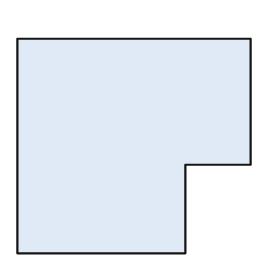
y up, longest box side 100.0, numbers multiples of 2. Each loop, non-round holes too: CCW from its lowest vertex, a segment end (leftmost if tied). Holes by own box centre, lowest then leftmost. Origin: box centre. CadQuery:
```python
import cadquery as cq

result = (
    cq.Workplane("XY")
    .moveTo(-50.0, -46.0)
    .lineTo(22.0, -46.0)
    .lineTo(22.0, -8.0)
    .lineTo(50.0, -8.0)
    .lineTo(50.0, 46.0)
    .lineTo(-50.0, 46.0)
    .close()
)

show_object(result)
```